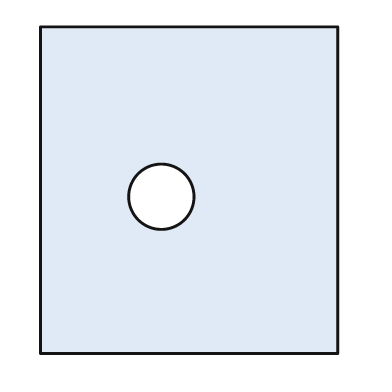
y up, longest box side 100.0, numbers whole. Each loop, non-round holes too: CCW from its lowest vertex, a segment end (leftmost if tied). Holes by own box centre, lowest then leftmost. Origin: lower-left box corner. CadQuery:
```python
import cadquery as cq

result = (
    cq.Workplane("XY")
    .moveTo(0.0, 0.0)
    .lineTo(91.0, 0.0)
    .lineTo(91.0, 100.0)
    .lineTo(0.0, 100.0)
    .close()
    .moveTo(37.0, 48.0)
    .circle(10.0)
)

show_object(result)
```